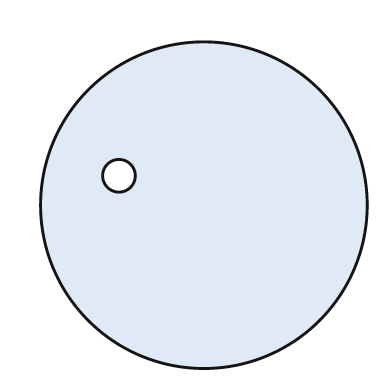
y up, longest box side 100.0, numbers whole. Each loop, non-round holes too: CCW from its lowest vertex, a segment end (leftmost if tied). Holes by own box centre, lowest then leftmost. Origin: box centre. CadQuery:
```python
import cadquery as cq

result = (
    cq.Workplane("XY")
    .moveTo(0.0, 0.0)
    .circle(50.0)
    .moveTo(-26.0, 9.0)
    .circle(5.0)
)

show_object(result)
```